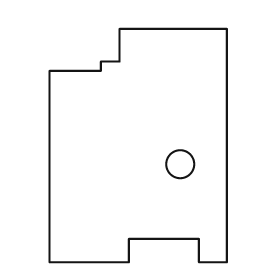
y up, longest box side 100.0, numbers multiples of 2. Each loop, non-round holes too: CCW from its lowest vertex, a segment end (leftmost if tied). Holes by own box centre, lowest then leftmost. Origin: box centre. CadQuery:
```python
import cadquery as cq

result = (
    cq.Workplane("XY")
    .moveTo(-38.0, -50.0)
    .lineTo(-4.0, -50.0)
    .lineTo(-4.0, -40.0)
    .lineTo(26.0, -40.0)
    .lineTo(26.0, -50.0)
    .lineTo(38.0, -50.0)
    .lineTo(38.0, 50.0)
    .lineTo(-8.0, 50.0)
    .lineTo(-8.0, 36.0)
    .lineTo(-16.0, 36.0)
    .lineTo(-16.0, 32.0)
    .lineTo(-38.0, 32.0)
    .close()
    .moveTo(18.0, -8.0)
    .circle(6.0)
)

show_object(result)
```